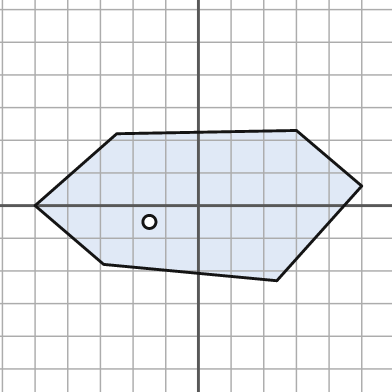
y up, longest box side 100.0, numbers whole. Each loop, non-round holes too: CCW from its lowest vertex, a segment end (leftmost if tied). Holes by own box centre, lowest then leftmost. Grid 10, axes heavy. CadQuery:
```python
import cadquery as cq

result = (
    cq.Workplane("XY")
    .moveTo(24.0, -23.0)
    .lineTo(50.0, 6.0)
    .lineTo(30.0, 23.0)
    .lineTo(-25.0, 22.0)
    .lineTo(-50.0, 0.0)
    .lineTo(-29.0, -18.0)
    .close()
    .moveTo(-15.0, -5.0)
    .circle(2.0)
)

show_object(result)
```